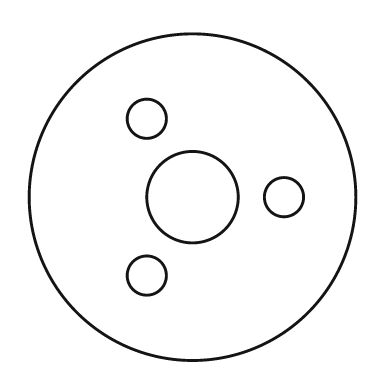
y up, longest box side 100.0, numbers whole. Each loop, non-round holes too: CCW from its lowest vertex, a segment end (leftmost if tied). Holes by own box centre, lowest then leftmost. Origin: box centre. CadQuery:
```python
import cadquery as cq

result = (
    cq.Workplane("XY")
    .moveTo(0.0, 0.0)
    .circle(50.0)
    .moveTo(-14.0, -24.0)
    .circle(6.0)
    .moveTo(0.0, 0.0)
    .circle(14.0)
    .moveTo(28.0, 0.0)
    .circle(6.0)
    .moveTo(-14.0, 24.0)
    .circle(6.0)
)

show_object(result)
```